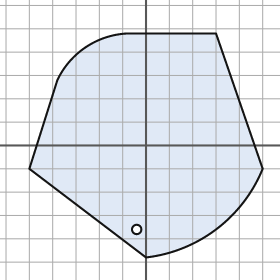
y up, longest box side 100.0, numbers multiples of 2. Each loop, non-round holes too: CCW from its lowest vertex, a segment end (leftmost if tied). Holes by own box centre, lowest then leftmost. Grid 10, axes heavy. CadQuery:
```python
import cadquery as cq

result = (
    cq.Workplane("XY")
    .moveTo(0.0, -48.0)
    .threePointArc((30.0, -36.0), (50.0, -10.0))
    .lineTo(30.0, 48.0)
    .lineTo(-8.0, 48.0)
    .threePointArc((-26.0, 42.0), (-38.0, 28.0))
    .lineTo(-50.0, -10.0)
    .close()
    .moveTo(-4.0, -36.0)
    .circle(2.0)
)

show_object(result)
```